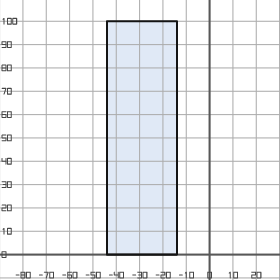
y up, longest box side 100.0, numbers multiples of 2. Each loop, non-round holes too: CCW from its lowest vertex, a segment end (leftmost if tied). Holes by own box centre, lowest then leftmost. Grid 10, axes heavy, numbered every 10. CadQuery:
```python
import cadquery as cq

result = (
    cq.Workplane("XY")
    .moveTo(-44.0, 0.0)
    .lineTo(-14.0, 0.0)
    .lineTo(-14.0, 100.0)
    .lineTo(-44.0, 100.0)
    .close()
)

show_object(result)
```